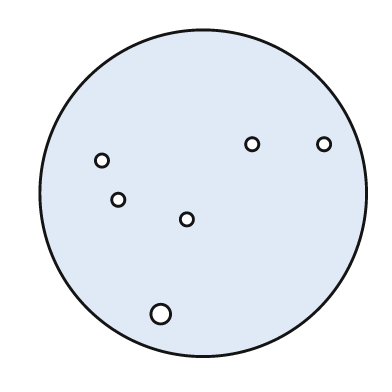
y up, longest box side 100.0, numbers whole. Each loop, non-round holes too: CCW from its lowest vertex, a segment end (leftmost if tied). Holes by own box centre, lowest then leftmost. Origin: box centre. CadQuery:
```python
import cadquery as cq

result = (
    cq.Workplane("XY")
    .moveTo(0.0, 0.0)
    .circle(50.0)
    .moveTo(-13.0, -37.0)
    .circle(3.0)
    .moveTo(-5.0, -8.0)
    .circle(2.0)
    .moveTo(-26.0, -2.0)
    .circle(2.0)
    .moveTo(-31.0, 10.0)
    .circle(2.0)
    .moveTo(15.0, 15.0)
    .circle(2.0)
    .moveTo(37.0, 15.0)
    .circle(2.0)
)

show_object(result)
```